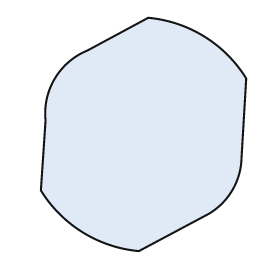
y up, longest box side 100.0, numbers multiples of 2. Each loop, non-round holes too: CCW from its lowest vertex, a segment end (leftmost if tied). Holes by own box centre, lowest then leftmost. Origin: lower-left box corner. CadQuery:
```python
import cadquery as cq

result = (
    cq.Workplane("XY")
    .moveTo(42.0, 0.0)
    .lineTo(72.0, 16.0)
    .threePointArc((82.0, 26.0), (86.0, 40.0))
    .lineTo(88.0, 74.0)
    .threePointArc((70.0, 92.0), (46.0, 100.0))
    .lineTo(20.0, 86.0)
    .threePointArc((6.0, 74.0), (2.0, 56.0))
    .lineTo(0.0, 26.0)
    .threePointArc((18.0, 8.0), (42.0, 0.0))
    .close()
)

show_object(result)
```